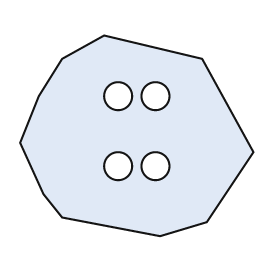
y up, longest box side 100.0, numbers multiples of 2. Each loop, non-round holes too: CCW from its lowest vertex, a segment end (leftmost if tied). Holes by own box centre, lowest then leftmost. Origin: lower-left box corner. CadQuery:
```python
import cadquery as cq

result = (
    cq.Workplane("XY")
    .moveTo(60.0, 0.0)
    .lineTo(80.0, 6.0)
    .lineTo(100.0, 36.0)
    .lineTo(78.0, 76.0)
    .lineTo(36.0, 86.0)
    .lineTo(18.0, 76.0)
    .lineTo(8.0, 60.0)
    .lineTo(0.0, 40.0)
    .lineTo(10.0, 18.0)
    .lineTo(18.0, 8.0)
    .close()
    .moveTo(42.0, 30.0)
    .circle(6.0)
    .moveTo(58.0, 30.0)
    .circle(6.0)
    .moveTo(42.0, 60.0)
    .circle(6.0)
    .moveTo(58.0, 60.0)
    .circle(6.0)
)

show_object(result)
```